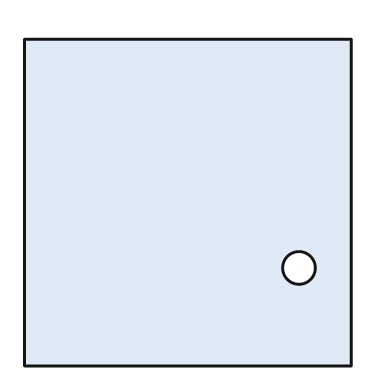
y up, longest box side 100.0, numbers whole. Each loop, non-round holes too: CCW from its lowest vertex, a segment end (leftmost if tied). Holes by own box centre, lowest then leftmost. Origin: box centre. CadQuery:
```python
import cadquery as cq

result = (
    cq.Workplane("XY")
    .moveTo(-50.0, -50.0)
    .lineTo(50.0, -50.0)
    .lineTo(50.0, 50.0)
    .lineTo(-50.0, 50.0)
    .close()
    .moveTo(34.0, -20.0)
    .circle(5.0)
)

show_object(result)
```